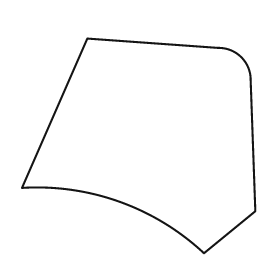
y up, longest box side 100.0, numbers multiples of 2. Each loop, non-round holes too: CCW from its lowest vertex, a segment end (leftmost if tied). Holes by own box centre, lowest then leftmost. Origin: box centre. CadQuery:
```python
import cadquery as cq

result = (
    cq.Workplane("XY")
    .moveTo(28.0, -46.0)
    .lineTo(50.0, -28.0)
    .lineTo(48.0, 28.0)
    .threePointArc((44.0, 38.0), (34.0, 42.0))
    .lineTo(-22.0, 46.0)
    .lineTo(-50.0, -18.0)
    .threePointArc((-8.0, -24.0), (28.0, -46.0))
    .close()
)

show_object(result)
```